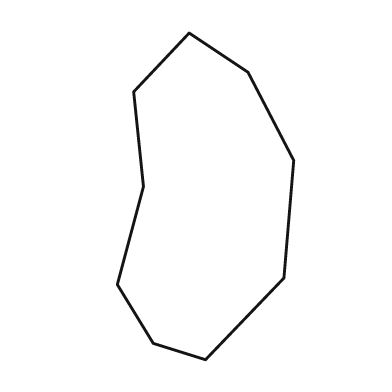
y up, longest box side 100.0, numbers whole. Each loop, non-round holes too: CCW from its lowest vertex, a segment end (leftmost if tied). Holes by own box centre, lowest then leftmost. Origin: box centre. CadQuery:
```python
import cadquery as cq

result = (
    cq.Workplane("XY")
    .moveTo(0.0, -50.0)
    .lineTo(24.0, -25.0)
    .lineTo(27.0, 11.0)
    .lineTo(13.0, 38.0)
    .lineTo(-5.0, 50.0)
    .lineTo(-22.0, 32.0)
    .lineTo(-19.0, 3.0)
    .lineTo(-27.0, -27.0)
    .lineTo(-16.0, -45.0)
    .close()
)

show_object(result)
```